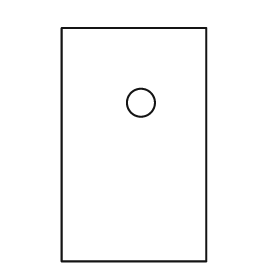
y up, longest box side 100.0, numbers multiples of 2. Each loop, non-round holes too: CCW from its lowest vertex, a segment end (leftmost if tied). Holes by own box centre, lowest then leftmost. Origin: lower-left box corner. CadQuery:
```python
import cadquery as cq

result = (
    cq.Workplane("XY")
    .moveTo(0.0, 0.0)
    .lineTo(62.0, 0.0)
    .lineTo(62.0, 100.0)
    .lineTo(0.0, 100.0)
    .close()
    .moveTo(34.0, 68.0)
    .circle(6.0)
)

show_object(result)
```